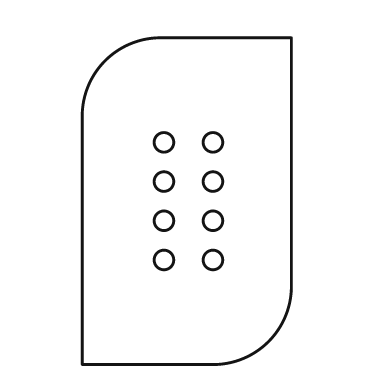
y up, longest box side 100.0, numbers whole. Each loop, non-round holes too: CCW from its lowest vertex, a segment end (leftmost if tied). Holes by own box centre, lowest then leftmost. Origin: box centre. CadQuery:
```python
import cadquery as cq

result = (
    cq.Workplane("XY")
    .moveTo(-32.0, -50.0)
    .lineTo(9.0, -50.0)
    .threePointArc((25.0, -43.0), (32.0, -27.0))
    .lineTo(32.0, 50.0)
    .lineTo(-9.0, 50.0)
    .threePointArc((-25.0, 43.0), (-32.0, 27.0))
    .close()
    .moveTo(-7.0, -18.0)
    .circle(3.0)
    .moveTo(8.0, -18.0)
    .circle(3.0)
    .moveTo(-7.0, -6.0)
    .circle(3.0)
    .moveTo(8.0, -6.0)
    .circle(3.0)
    .moveTo(-7.0, 6.0)
    .circle(3.0)
    .moveTo(8.0, 6.0)
    .circle(3.0)
    .moveTo(-7.0, 18.0)
    .circle(3.0)
    .moveTo(8.0, 18.0)
    .circle(3.0)
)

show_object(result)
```